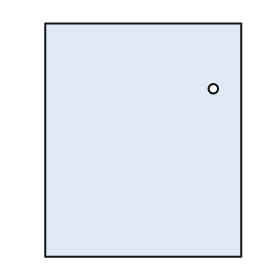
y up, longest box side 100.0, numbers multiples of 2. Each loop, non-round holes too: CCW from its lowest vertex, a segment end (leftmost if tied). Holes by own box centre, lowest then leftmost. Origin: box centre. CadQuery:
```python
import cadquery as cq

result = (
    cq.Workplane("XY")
    .moveTo(-42.0, -50.0)
    .lineTo(42.0, -50.0)
    .lineTo(42.0, 50.0)
    .lineTo(-42.0, 50.0)
    .close()
    .moveTo(30.0, 22.0)
    .circle(2.0)
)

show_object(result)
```